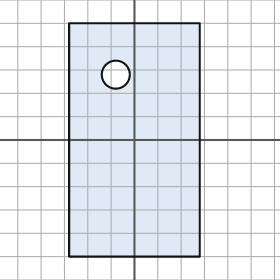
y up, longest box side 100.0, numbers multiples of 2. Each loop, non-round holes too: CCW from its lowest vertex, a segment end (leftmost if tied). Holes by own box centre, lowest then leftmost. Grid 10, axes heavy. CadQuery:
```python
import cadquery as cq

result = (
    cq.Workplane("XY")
    .moveTo(-28.0, -50.0)
    .lineTo(28.0, -50.0)
    .lineTo(28.0, 50.0)
    .lineTo(-28.0, 50.0)
    .close()
    .moveTo(-8.0, 28.0)
    .circle(6.0)
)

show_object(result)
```